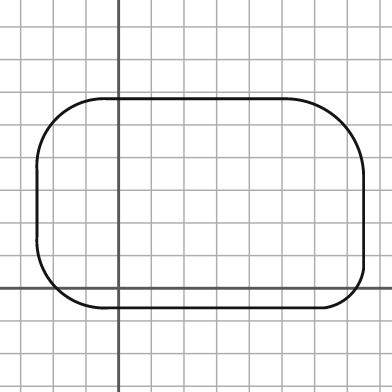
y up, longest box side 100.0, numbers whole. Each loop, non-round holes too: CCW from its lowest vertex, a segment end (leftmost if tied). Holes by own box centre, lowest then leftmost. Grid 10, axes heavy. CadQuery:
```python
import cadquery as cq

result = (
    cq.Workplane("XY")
    .moveTo(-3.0, -6.0)
    .lineTo(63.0, -6.0)
    .threePointArc((71.0, -2.0), (75.0, 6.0))
    .lineTo(75.0, 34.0)
    .threePointArc((68.0, 51.0), (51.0, 58.0))
    .lineTo(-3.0, 58.0)
    .threePointArc((-19.0, 52.0), (-25.0, 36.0))
    .lineTo(-25.0, 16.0)
    .threePointArc((-19.0, 0.0), (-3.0, -6.0))
    .close()
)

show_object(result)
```